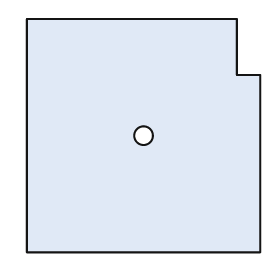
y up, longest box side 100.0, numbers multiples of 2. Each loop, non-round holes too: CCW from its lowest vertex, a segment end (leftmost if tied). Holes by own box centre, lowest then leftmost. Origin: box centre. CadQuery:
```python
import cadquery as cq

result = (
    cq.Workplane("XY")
    .moveTo(-50.0, -50.0)
    .lineTo(50.0, -50.0)
    .lineTo(50.0, 26.0)
    .lineTo(40.0, 26.0)
    .lineTo(40.0, 50.0)
    .lineTo(-50.0, 50.0)
    .close()
    .moveTo(0.0, 0.0)
    .circle(4.0)
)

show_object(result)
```